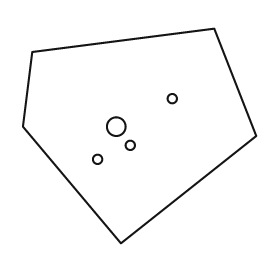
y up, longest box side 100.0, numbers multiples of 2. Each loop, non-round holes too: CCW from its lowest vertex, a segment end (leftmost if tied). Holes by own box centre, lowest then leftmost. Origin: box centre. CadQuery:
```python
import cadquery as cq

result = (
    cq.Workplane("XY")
    .moveTo(-8.0, -46.0)
    .lineTo(50.0, 0.0)
    .lineTo(32.0, 46.0)
    .lineTo(-46.0, 36.0)
    .lineTo(-50.0, 4.0)
    .close()
    .moveTo(-18.0, -10.0)
    .circle(2.0)
    .moveTo(-4.0, -4.0)
    .circle(2.0)
    .moveTo(-10.0, 4.0)
    .circle(4.0)
    .moveTo(14.0, 16.0)
    .circle(2.0)
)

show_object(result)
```